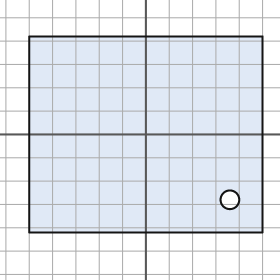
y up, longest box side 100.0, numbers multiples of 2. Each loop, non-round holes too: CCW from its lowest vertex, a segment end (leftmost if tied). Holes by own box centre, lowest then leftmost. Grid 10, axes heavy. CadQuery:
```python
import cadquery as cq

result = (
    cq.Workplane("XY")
    .moveTo(-50.0, -42.0)
    .lineTo(50.0, -42.0)
    .lineTo(50.0, 42.0)
    .lineTo(-50.0, 42.0)
    .close()
    .moveTo(36.0, -28.0)
    .circle(4.0)
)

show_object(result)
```